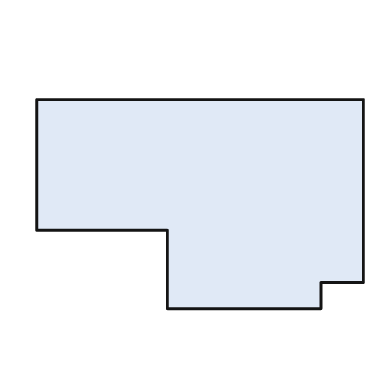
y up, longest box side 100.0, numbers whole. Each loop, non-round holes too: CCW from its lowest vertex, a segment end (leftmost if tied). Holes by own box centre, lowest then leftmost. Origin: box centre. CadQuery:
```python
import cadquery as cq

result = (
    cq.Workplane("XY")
    .moveTo(-10.0, -32.0)
    .lineTo(37.0, -32.0)
    .lineTo(37.0, -24.0)
    .lineTo(50.0, -24.0)
    .lineTo(50.0, 32.0)
    .lineTo(-50.0, 32.0)
    .lineTo(-50.0, -8.0)
    .lineTo(-10.0, -8.0)
    .close()
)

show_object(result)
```